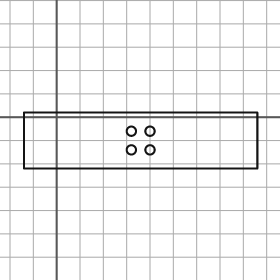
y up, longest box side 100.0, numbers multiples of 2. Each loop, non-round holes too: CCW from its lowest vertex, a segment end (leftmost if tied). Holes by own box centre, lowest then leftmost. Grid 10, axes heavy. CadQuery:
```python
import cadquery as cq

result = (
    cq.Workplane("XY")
    .moveTo(-14.0, -22.0)
    .lineTo(86.0, -22.0)
    .lineTo(86.0, 2.0)
    .lineTo(-14.0, 2.0)
    .close()
    .moveTo(32.0, -14.0)
    .circle(2.0)
    .moveTo(40.0, -14.0)
    .circle(2.0)
    .moveTo(32.0, -6.0)
    .circle(2.0)
    .moveTo(40.0, -6.0)
    .circle(2.0)
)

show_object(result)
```